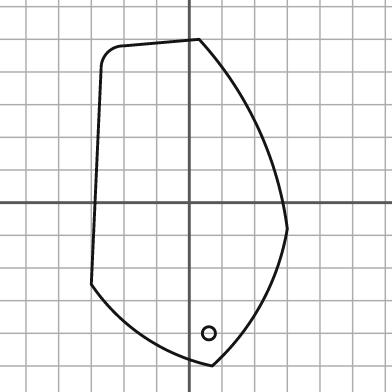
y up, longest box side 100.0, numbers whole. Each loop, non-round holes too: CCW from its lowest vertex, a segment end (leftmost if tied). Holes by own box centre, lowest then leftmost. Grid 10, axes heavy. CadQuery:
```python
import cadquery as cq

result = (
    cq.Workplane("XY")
    .moveTo(7.0, -50.0)
    .threePointArc((22.0, -31.0), (30.0, -8.0))
    .threePointArc((21.0, 23.0), (3.0, 50.0))
    .lineTo(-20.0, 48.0)
    .threePointArc((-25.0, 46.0), (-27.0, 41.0))
    .lineTo(-30.0, -25.0)
    .threePointArc((-14.0, -41.0), (7.0, -50.0))
    .close()
    .moveTo(6.0, -40.0)
    .circle(2.0)
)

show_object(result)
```